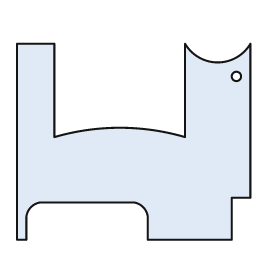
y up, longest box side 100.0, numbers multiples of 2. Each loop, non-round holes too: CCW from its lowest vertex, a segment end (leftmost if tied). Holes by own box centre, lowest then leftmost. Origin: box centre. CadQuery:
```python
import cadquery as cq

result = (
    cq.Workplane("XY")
    .moveTo(-50.0, -42.0)
    .lineTo(-46.0, -42.0)
    .lineTo(-46.0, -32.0)
    .threePointArc((-44.0, -28.0), (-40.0, -26.0))
    .lineTo(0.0, -26.0)
    .threePointArc((4.0, -28.0), (6.0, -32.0))
    .lineTo(6.0, -42.0)
    .lineTo(42.0, -42.0)
    .lineTo(42.0, -24.0)
    .lineTo(50.0, -24.0)
    .lineTo(50.0, 42.0)
    .threePointArc((36.0, 34.0), (22.0, 42.0))
    .lineTo(22.0, 2.0)
    .threePointArc((-6.0, 6.0), (-34.0, 2.0))
    .lineTo(-34.0, 42.0)
    .lineTo(-50.0, 42.0)
    .close()
    .moveTo(44.0, 28.0)
    .circle(2.0)
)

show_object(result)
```